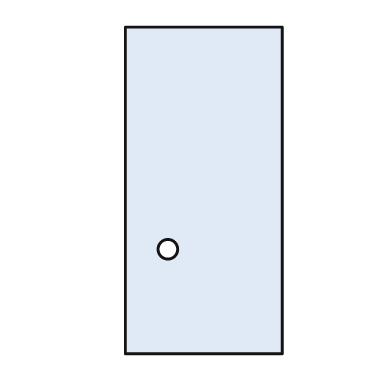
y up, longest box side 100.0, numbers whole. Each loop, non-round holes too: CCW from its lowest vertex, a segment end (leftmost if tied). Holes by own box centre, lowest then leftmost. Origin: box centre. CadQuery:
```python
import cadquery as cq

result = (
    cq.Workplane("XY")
    .moveTo(-24.0, -50.0)
    .lineTo(24.0, -50.0)
    .lineTo(24.0, 50.0)
    .lineTo(-24.0, 50.0)
    .close()
    .moveTo(-11.0, -18.0)
    .circle(3.0)
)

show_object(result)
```